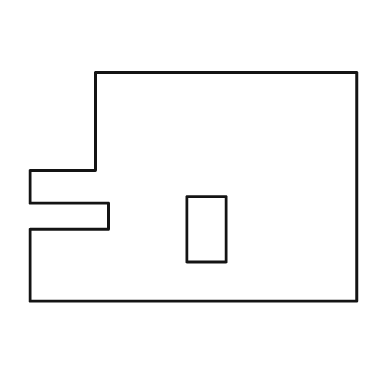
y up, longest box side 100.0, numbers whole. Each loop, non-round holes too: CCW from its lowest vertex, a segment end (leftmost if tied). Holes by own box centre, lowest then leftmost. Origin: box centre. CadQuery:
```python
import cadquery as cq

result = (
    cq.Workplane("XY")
    .moveTo(-50.0, -35.0)
    .lineTo(50.0, -35.0)
    .lineTo(50.0, 35.0)
    .lineTo(-30.0, 35.0)
    .lineTo(-30.0, 5.0)
    .lineTo(-50.0, 5.0)
    .lineTo(-50.0, -5.0)
    .lineTo(-26.0, -5.0)
    .lineTo(-26.0, -13.0)
    .lineTo(-50.0, -13.0)
    .close()
    .moveTo(-2.0, -23.0)
    .lineTo(10.0, -23.0)
    .lineTo(10.0, -3.0)
    .lineTo(-2.0, -3.0)
    .close()
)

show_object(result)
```